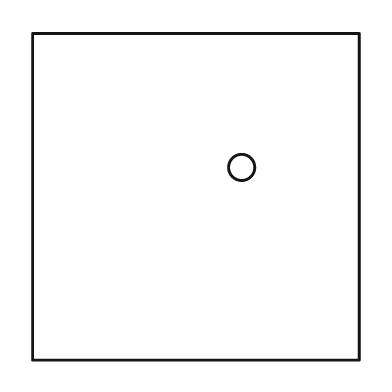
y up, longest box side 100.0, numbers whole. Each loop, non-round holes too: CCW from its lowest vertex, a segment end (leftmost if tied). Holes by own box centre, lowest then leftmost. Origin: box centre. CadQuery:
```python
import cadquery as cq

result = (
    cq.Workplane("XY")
    .moveTo(-50.0, -50.0)
    .lineTo(50.0, -50.0)
    .lineTo(50.0, 50.0)
    .lineTo(-50.0, 50.0)
    .close()
    .moveTo(14.0, 9.0)
    .circle(4.0)
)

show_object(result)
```